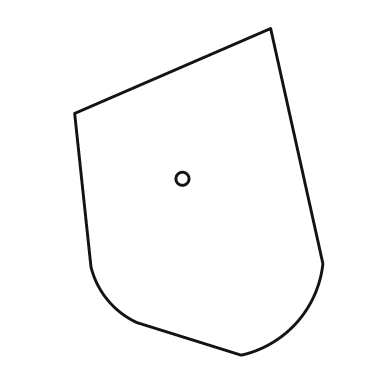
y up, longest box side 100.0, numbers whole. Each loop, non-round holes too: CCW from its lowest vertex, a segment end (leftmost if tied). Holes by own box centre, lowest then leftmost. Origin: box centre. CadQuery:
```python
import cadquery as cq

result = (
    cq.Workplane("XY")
    .moveTo(13.0, -50.0)
    .threePointArc((30.0, -40.0), (38.0, -22.0))
    .lineTo(22.0, 50.0)
    .lineTo(-38.0, 24.0)
    .lineTo(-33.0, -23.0)
    .threePointArc((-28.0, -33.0), (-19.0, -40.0))
    .close()
    .moveTo(-5.0, 4.0)
    .circle(2.0)
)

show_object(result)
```